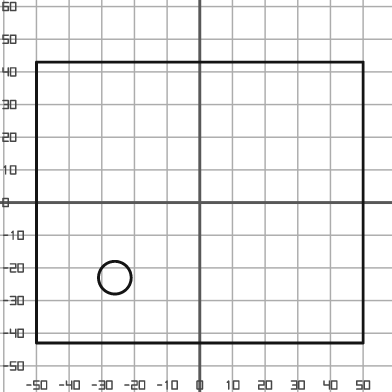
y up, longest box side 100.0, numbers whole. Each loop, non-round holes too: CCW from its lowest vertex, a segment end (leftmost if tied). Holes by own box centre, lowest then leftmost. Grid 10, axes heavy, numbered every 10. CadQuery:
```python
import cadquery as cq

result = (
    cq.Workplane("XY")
    .moveTo(-50.0, -43.0)
    .lineTo(50.0, -43.0)
    .lineTo(50.0, 43.0)
    .lineTo(-50.0, 43.0)
    .close()
    .moveTo(-26.0, -23.0)
    .circle(5.0)
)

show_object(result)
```